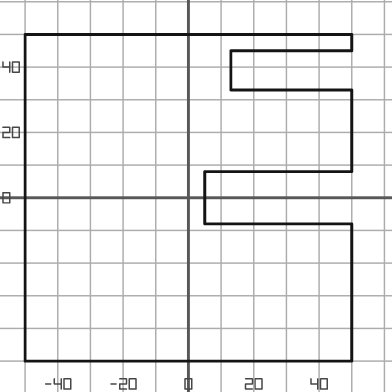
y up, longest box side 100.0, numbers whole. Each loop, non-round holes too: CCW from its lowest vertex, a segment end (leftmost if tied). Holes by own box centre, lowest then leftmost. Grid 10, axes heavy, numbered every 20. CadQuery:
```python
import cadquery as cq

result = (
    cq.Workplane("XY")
    .moveTo(-50.0, -50.0)
    .lineTo(50.0, -50.0)
    .lineTo(50.0, -8.0)
    .lineTo(5.0, -8.0)
    .lineTo(5.0, 8.0)
    .lineTo(50.0, 8.0)
    .lineTo(50.0, 33.0)
    .lineTo(13.0, 33.0)
    .lineTo(13.0, 45.0)
    .lineTo(50.0, 45.0)
    .lineTo(50.0, 50.0)
    .lineTo(-50.0, 50.0)
    .close()
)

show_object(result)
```